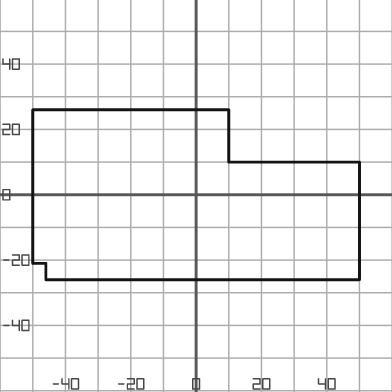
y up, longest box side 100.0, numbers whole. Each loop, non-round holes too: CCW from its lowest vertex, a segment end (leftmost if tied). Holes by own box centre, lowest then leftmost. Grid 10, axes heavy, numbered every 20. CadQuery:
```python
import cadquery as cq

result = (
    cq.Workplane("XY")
    .moveTo(-46.0, -26.0)
    .lineTo(50.0, -26.0)
    .lineTo(50.0, 10.0)
    .lineTo(10.0, 10.0)
    .lineTo(10.0, 26.0)
    .lineTo(-50.0, 26.0)
    .lineTo(-50.0, -21.0)
    .lineTo(-46.0, -21.0)
    .close()
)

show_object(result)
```